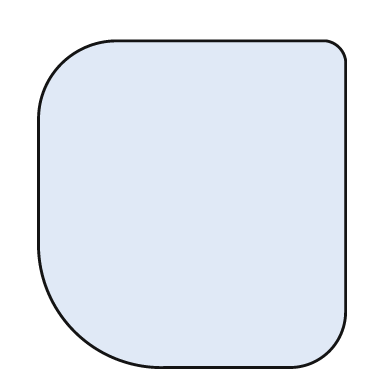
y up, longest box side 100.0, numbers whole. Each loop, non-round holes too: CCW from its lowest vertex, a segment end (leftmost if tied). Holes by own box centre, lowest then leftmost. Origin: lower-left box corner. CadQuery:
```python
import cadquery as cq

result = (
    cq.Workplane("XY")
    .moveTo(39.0, 0.0)
    .lineTo(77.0, 0.0)
    .threePointArc((89.0, 5.0), (94.0, 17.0))
    .lineTo(94.0, 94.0)
    .threePointArc((92.0, 98.0), (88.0, 100.0))
    .lineTo(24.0, 100.0)
    .threePointArc((7.0, 93.0), (0.0, 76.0))
    .lineTo(0.0, 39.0)
    .threePointArc((11.0, 11.0), (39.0, 0.0))
    .close()
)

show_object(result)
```